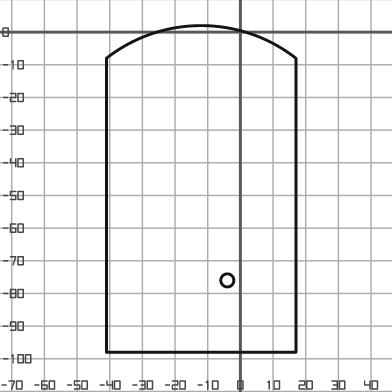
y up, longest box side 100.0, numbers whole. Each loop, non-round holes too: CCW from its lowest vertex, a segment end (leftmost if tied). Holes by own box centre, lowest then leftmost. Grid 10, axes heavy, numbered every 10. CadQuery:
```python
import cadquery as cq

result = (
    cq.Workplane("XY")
    .moveTo(-41.0, -98.0)
    .lineTo(17.0, -98.0)
    .lineTo(17.0, -8.0)
    .threePointArc((-12.0, 2.0), (-41.0, -8.0))
    .close()
    .moveTo(-4.0, -76.0)
    .circle(2.0)
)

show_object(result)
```